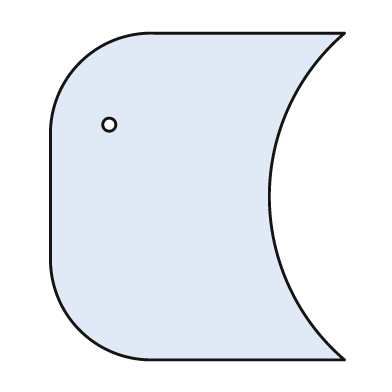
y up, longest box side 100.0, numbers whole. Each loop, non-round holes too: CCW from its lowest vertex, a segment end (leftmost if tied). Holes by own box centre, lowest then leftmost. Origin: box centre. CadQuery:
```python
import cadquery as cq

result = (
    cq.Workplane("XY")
    .moveTo(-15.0, -50.0)
    .lineTo(45.0, -50.0)
    .threePointArc((22.0, 0.0), (45.0, 50.0))
    .lineTo(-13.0, 50.0)
    .threePointArc((-36.0, 41.0), (-45.0, 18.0))
    .lineTo(-45.0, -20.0)
    .threePointArc((-36.0, -41.0), (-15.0, -50.0))
    .close()
    .moveTo(-27.0, 22.0)
    .circle(2.0)
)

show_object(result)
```